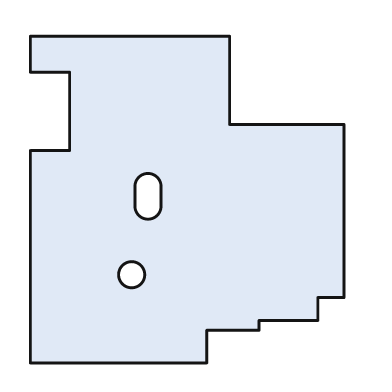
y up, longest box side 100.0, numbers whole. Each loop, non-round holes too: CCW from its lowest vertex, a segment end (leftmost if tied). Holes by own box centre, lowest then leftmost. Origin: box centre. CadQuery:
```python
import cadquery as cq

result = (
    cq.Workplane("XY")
    .moveTo(-48.0, -50.0)
    .lineTo(6.0, -50.0)
    .lineTo(6.0, -40.0)
    .lineTo(22.0, -40.0)
    .lineTo(22.0, -37.0)
    .lineTo(40.0, -37.0)
    .lineTo(40.0, -30.0)
    .lineTo(48.0, -30.0)
    .lineTo(48.0, 23.0)
    .lineTo(13.0, 23.0)
    .lineTo(13.0, 50.0)
    .lineTo(-48.0, 50.0)
    .lineTo(-48.0, 39.0)
    .lineTo(-36.0, 39.0)
    .lineTo(-36.0, 15.0)
    .lineTo(-48.0, 15.0)
    .close()
    .moveTo(-17.0, -23.0)
    .circle(4.0)
    .moveTo(-16.0, -2.0)
    .threePointArc((-12.0, -6.0), (-8.0, -2.0))
    .lineTo(-8.0, 4.0)
    .threePointArc((-12.0, 8.0), (-16.0, 4.0))
    .close()
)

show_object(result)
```